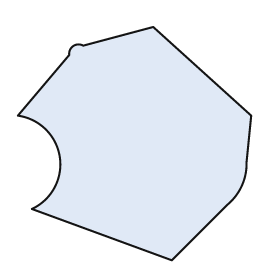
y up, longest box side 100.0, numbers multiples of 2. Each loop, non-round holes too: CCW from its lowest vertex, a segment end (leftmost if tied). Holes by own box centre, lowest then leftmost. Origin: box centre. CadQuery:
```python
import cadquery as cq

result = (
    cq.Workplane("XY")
    .moveTo(16.0, -50.0)
    .lineTo(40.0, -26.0)
    .threePointArc((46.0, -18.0), (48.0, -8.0))
    .lineTo(50.0, 12.0)
    .lineTo(8.0, 50.0)
    .lineTo(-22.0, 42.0)
    .threePointArc((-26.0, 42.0), (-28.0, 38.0))
    .lineTo(-50.0, 12.0)
    .threePointArc((-32.0, -6.0), (-44.0, -28.0))
    .close()
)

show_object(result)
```